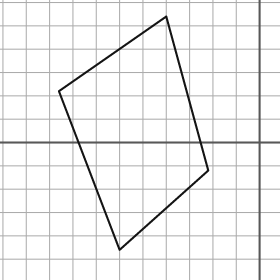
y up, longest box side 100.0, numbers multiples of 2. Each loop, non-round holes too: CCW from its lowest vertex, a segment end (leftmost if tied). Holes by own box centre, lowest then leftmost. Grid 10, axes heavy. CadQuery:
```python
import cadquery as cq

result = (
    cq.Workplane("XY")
    .moveTo(-60.0, -46.0)
    .lineTo(-22.0, -12.0)
    .lineTo(-40.0, 54.0)
    .lineTo(-86.0, 22.0)
    .close()
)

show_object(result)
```